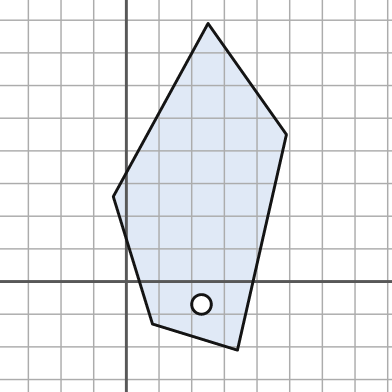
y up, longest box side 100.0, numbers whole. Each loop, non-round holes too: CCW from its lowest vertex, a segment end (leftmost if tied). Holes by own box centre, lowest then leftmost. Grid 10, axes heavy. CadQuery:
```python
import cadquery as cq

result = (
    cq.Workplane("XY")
    .moveTo(34.0, -21.0)
    .lineTo(49.0, 45.0)
    .lineTo(25.0, 79.0)
    .lineTo(-4.0, 26.0)
    .lineTo(8.0, -13.0)
    .close()
    .moveTo(23.0, -7.0)
    .circle(3.0)
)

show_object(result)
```